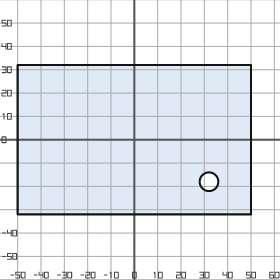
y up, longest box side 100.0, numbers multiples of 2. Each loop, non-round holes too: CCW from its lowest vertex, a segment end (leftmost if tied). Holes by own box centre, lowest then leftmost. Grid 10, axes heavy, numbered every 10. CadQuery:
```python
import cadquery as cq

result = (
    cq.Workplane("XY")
    .moveTo(-50.0, -32.0)
    .lineTo(50.0, -32.0)
    .lineTo(50.0, 32.0)
    .lineTo(-50.0, 32.0)
    .close()
    .moveTo(32.0, -18.0)
    .circle(4.0)
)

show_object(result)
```